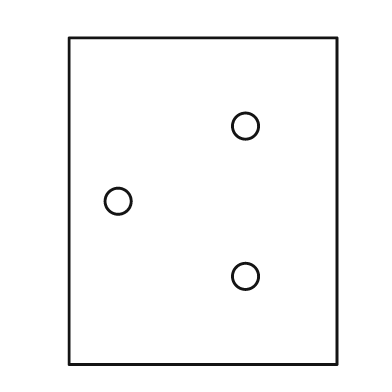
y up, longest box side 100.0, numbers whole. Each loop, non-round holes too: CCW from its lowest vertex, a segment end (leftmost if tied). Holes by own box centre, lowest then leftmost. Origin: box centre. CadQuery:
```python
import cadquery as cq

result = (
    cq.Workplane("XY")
    .moveTo(-41.0, -50.0)
    .lineTo(41.0, -50.0)
    .lineTo(41.0, 50.0)
    .lineTo(-41.0, 50.0)
    .close()
    .moveTo(13.0, -23.0)
    .circle(4.0)
    .moveTo(-26.0, 0.0)
    .circle(4.0)
    .moveTo(13.0, 23.0)
    .circle(4.0)
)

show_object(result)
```